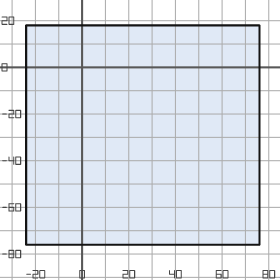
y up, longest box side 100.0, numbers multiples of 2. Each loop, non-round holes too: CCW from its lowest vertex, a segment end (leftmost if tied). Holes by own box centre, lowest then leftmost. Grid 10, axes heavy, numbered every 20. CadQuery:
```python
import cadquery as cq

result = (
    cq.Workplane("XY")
    .moveTo(-24.0, -76.0)
    .lineTo(76.0, -76.0)
    .lineTo(76.0, 18.0)
    .lineTo(-24.0, 18.0)
    .close()
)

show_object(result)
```